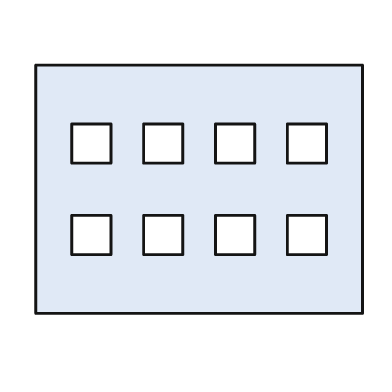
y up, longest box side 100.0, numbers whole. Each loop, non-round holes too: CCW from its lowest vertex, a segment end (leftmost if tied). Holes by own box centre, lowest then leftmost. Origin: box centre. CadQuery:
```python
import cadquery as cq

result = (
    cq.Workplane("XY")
    .moveTo(-50.0, -38.0)
    .lineTo(50.0, -38.0)
    .lineTo(50.0, 38.0)
    .lineTo(-50.0, 38.0)
    .close()
    .moveTo(-39.0, -20.0)
    .lineTo(-27.0, -20.0)
    .lineTo(-27.0, -8.0)
    .lineTo(-39.0, -8.0)
    .close()
    .moveTo(-17.0, -20.0)
    .lineTo(-5.0, -20.0)
    .lineTo(-5.0, -8.0)
    .lineTo(-17.0, -8.0)
    .close()
    .moveTo(5.0, -20.0)
    .lineTo(17.0, -20.0)
    .lineTo(17.0, -8.0)
    .lineTo(5.0, -8.0)
    .close()
    .moveTo(27.0, -20.0)
    .lineTo(39.0, -20.0)
    .lineTo(39.0, -8.0)
    .lineTo(27.0, -8.0)
    .close()
    .moveTo(-39.0, 8.0)
    .lineTo(-27.0, 8.0)
    .lineTo(-27.0, 20.0)
    .lineTo(-39.0, 20.0)
    .close()
    .moveTo(-17.0, 8.0)
    .lineTo(-5.0, 8.0)
    .lineTo(-5.0, 20.0)
    .lineTo(-17.0, 20.0)
    .close()
    .moveTo(5.0, 8.0)
    .lineTo(17.0, 8.0)
    .lineTo(17.0, 20.0)
    .lineTo(5.0, 20.0)
    .close()
    .moveTo(27.0, 8.0)
    .lineTo(39.0, 8.0)
    .lineTo(39.0, 20.0)
    .lineTo(27.0, 20.0)
    .close()
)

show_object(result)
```